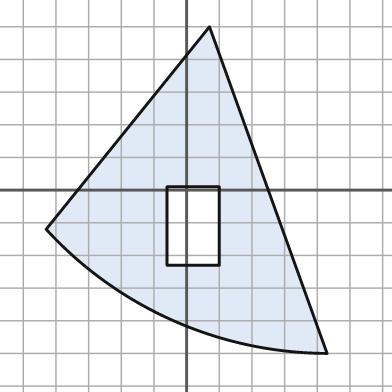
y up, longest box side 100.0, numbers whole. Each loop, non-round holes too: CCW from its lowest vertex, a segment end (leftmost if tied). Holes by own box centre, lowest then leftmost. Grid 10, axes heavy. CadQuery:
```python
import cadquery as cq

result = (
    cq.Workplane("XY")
    .moveTo(43.0, -50.0)
    .lineTo(7.0, 50.0)
    .lineTo(-43.0, -12.0)
    .threePointArc((-4.0, -40.0), (43.0, -50.0))
    .close()
    .moveTo(-6.0, -23.0)
    .lineTo(10.0, -23.0)
    .lineTo(10.0, 1.0)
    .lineTo(-6.0, 1.0)
    .close()
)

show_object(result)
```